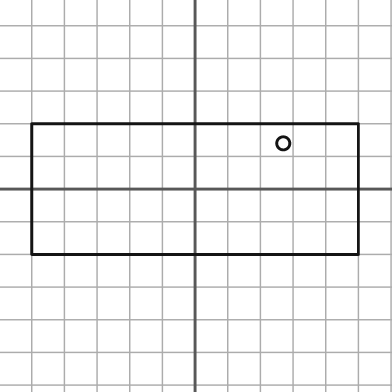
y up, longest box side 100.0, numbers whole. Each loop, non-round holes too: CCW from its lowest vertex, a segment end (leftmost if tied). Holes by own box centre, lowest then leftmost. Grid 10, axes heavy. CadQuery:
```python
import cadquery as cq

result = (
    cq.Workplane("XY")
    .moveTo(-50.0, -20.0)
    .lineTo(50.0, -20.0)
    .lineTo(50.0, 20.0)
    .lineTo(-50.0, 20.0)
    .close()
    .moveTo(27.0, 14.0)
    .circle(2.0)
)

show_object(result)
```